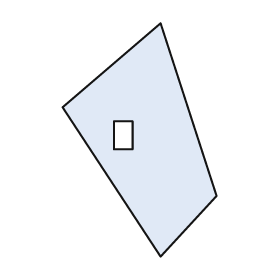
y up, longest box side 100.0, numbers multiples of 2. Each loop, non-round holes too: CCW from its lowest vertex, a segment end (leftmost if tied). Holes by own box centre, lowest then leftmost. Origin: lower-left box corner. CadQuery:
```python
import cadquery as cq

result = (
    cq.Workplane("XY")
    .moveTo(42.0, 0.0)
    .lineTo(66.0, 26.0)
    .lineTo(42.0, 100.0)
    .lineTo(0.0, 64.0)
    .close()
    .moveTo(22.0, 46.0)
    .lineTo(30.0, 46.0)
    .lineTo(30.0, 58.0)
    .lineTo(22.0, 58.0)
    .close()
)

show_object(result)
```